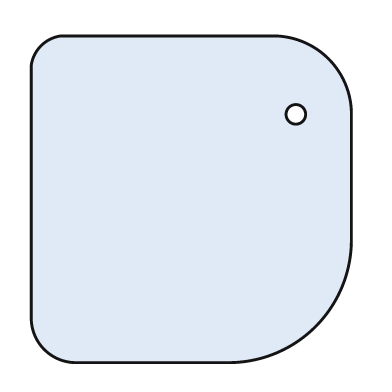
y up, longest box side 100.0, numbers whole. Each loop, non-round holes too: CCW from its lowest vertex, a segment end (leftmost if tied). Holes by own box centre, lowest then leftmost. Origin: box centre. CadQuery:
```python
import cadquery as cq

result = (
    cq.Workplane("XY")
    .moveTo(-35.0, -50.0)
    .lineTo(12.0, -50.0)
    .threePointArc((38.0, -39.0), (49.0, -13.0))
    .lineTo(49.0, 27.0)
    .threePointArc((42.0, 43.0), (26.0, 50.0))
    .lineTo(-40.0, 50.0)
    .threePointArc((-46.0, 47.0), (-49.0, 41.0))
    .lineTo(-49.0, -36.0)
    .threePointArc((-45.0, -46.0), (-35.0, -50.0))
    .close()
    .moveTo(32.0, 26.0)
    .circle(3.0)
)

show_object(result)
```